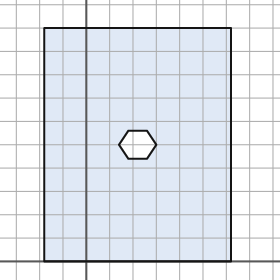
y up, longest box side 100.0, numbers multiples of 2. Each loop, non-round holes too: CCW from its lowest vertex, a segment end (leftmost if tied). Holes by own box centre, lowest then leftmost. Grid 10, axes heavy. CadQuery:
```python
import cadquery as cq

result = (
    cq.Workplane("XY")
    .moveTo(-18.0, 0.0)
    .lineTo(62.0, 0.0)
    .lineTo(62.0, 100.0)
    .lineTo(-18.0, 100.0)
    .close()
    .moveTo(18.0, 44.0)
    .lineTo(26.0, 44.0)
    .lineTo(30.0, 50.0)
    .lineTo(26.0, 56.0)
    .lineTo(18.0, 56.0)
    .lineTo(14.0, 50.0)
    .close()
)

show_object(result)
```